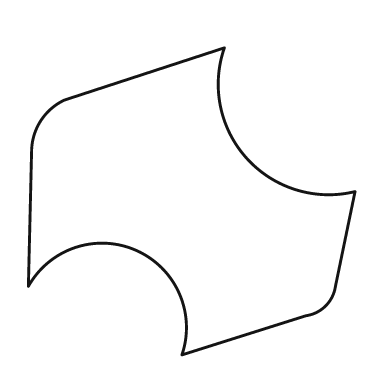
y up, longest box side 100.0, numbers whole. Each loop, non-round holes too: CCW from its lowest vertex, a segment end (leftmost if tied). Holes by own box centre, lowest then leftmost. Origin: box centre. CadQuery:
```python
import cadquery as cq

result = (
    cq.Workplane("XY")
    .moveTo(-3.0, -47.0)
    .lineTo(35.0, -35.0)
    .threePointArc((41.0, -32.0), (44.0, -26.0))
    .lineTo(50.0, 3.0)
    .threePointArc((17.0, 13.0), (10.0, 47.0))
    .lineTo(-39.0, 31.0)
    .threePointArc((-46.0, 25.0), (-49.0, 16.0))
    .lineTo(-50.0, -26.0)
    .threePointArc((-17.0, -15.0), (-3.0, -47.0))
    .close()
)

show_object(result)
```